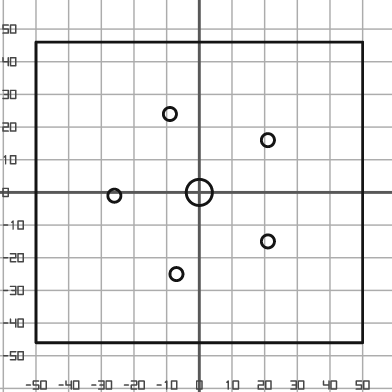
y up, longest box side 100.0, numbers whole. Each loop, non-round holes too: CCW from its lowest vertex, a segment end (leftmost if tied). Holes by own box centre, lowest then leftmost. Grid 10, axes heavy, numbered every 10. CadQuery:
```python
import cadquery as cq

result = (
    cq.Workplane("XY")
    .moveTo(-50.0, -46.0)
    .lineTo(50.0, -46.0)
    .lineTo(50.0, 46.0)
    .lineTo(-50.0, 46.0)
    .close()
    .moveTo(-7.0, -25.0)
    .circle(2.0)
    .moveTo(21.0, -15.0)
    .circle(2.0)
    .moveTo(-26.0, -1.0)
    .circle(2.0)
    .moveTo(0.0, 0.0)
    .circle(4.0)
    .moveTo(21.0, 16.0)
    .circle(2.0)
    .moveTo(-9.0, 24.0)
    .circle(2.0)
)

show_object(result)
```